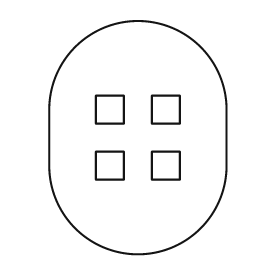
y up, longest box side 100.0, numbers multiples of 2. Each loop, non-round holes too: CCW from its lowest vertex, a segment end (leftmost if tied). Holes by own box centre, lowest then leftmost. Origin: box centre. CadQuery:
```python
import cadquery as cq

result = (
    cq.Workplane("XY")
    .moveTo(-38.0, -12.0)
    .threePointArc((0.0, -50.0), (38.0, -12.0))
    .lineTo(38.0, 12.0)
    .threePointArc((0.0, 50.0), (-38.0, 12.0))
    .close()
    .moveTo(-18.0, -18.0)
    .lineTo(-6.0, -18.0)
    .lineTo(-6.0, -6.0)
    .lineTo(-18.0, -6.0)
    .close()
    .moveTo(6.0, -18.0)
    .lineTo(18.0, -18.0)
    .lineTo(18.0, -6.0)
    .lineTo(6.0, -6.0)
    .close()
    .moveTo(-18.0, 6.0)
    .lineTo(-6.0, 6.0)
    .lineTo(-6.0, 18.0)
    .lineTo(-18.0, 18.0)
    .close()
    .moveTo(6.0, 6.0)
    .lineTo(18.0, 6.0)
    .lineTo(18.0, 18.0)
    .lineTo(6.0, 18.0)
    .close()
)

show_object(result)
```